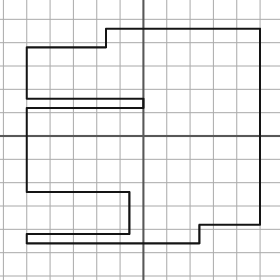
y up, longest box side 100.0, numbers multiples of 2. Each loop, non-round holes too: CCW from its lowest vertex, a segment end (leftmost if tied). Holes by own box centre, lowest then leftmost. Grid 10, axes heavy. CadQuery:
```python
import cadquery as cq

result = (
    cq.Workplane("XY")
    .moveTo(-50.0, -46.0)
    .lineTo(24.0, -46.0)
    .lineTo(24.0, -38.0)
    .lineTo(50.0, -38.0)
    .lineTo(50.0, 46.0)
    .lineTo(-16.0, 46.0)
    .lineTo(-16.0, 38.0)
    .lineTo(-50.0, 38.0)
    .lineTo(-50.0, 16.0)
    .lineTo(0.0, 16.0)
    .lineTo(0.0, 12.0)
    .lineTo(-50.0, 12.0)
    .lineTo(-50.0, -24.0)
    .lineTo(-6.0, -24.0)
    .lineTo(-6.0, -42.0)
    .lineTo(-50.0, -42.0)
    .close()
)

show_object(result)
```